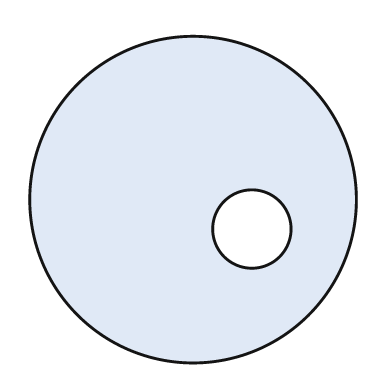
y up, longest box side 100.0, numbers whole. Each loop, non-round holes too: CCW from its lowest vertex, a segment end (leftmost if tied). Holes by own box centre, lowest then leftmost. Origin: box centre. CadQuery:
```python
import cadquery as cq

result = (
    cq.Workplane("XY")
    .moveTo(0.0, 0.0)
    .circle(50.0)
    .moveTo(18.0, -9.0)
    .circle(12.0)
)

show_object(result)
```